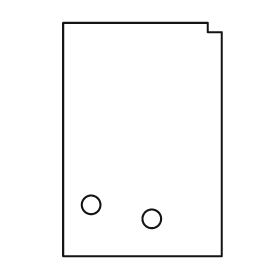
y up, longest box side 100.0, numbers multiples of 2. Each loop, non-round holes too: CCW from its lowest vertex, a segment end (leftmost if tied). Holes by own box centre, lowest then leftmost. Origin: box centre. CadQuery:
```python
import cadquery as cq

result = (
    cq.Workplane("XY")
    .moveTo(-34.0, -50.0)
    .lineTo(34.0, -50.0)
    .lineTo(34.0, 46.0)
    .lineTo(28.0, 46.0)
    .lineTo(28.0, 50.0)
    .lineTo(-34.0, 50.0)
    .close()
    .moveTo(4.0, -34.0)
    .circle(4.0)
    .moveTo(-22.0, -28.0)
    .circle(4.0)
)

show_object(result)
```